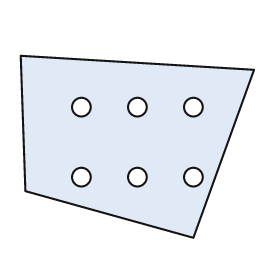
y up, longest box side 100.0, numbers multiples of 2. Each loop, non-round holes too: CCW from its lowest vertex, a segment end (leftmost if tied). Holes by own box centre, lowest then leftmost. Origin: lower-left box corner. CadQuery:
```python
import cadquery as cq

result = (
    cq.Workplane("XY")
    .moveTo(74.0, 0.0)
    .lineTo(100.0, 72.0)
    .lineTo(0.0, 78.0)
    .lineTo(2.0, 20.0)
    .close()
    .moveTo(26.0, 26.0)
    .circle(4.0)
    .moveTo(50.0, 26.0)
    .circle(4.0)
    .moveTo(74.0, 26.0)
    .circle(4.0)
    .moveTo(26.0, 56.0)
    .circle(4.0)
    .moveTo(50.0, 56.0)
    .circle(4.0)
    .moveTo(74.0, 56.0)
    .circle(4.0)
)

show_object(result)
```